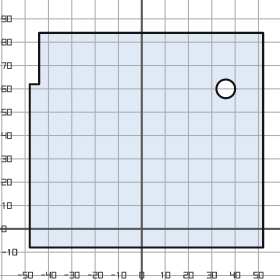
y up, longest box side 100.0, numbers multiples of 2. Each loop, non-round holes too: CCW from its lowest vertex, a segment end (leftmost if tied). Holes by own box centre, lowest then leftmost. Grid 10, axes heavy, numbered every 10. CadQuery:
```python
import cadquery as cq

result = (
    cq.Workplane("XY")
    .moveTo(-48.0, -8.0)
    .lineTo(52.0, -8.0)
    .lineTo(52.0, 84.0)
    .lineTo(-44.0, 84.0)
    .lineTo(-44.0, 62.0)
    .lineTo(-48.0, 62.0)
    .close()
    .moveTo(36.0, 60.0)
    .circle(4.0)
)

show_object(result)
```